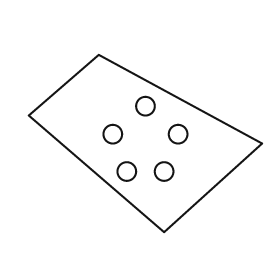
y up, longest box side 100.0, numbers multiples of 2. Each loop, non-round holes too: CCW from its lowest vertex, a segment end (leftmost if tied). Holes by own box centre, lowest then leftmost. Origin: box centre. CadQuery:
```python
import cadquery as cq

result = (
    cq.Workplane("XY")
    .moveTo(8.0, -38.0)
    .lineTo(50.0, 0.0)
    .lineTo(-20.0, 38.0)
    .lineTo(-50.0, 12.0)
    .close()
    .moveTo(-8.0, -12.0)
    .circle(4.0)
    .moveTo(8.0, -12.0)
    .circle(4.0)
    .moveTo(-14.0, 4.0)
    .circle(4.0)
    .moveTo(14.0, 4.0)
    .circle(4.0)
    .moveTo(0.0, 16.0)
    .circle(4.0)
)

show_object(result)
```